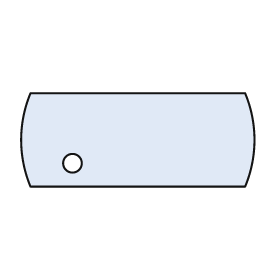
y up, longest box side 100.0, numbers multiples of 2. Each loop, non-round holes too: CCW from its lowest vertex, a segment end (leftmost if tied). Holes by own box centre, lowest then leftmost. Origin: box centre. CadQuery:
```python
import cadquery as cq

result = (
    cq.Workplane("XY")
    .moveTo(-46.0, -20.0)
    .lineTo(46.0, -20.0)
    .threePointArc((50.0, 0.0), (46.0, 20.0))
    .lineTo(-46.0, 20.0)
    .threePointArc((-50.0, 0.0), (-46.0, -20.0))
    .close()
    .moveTo(-28.0, -10.0)
    .circle(4.0)
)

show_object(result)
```